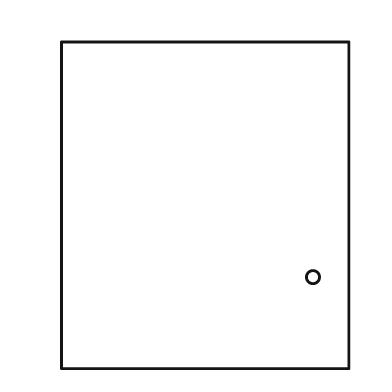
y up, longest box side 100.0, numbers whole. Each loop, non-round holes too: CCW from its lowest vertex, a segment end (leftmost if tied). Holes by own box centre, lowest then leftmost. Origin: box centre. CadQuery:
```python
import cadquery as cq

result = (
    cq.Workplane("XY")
    .moveTo(-44.0, -50.0)
    .lineTo(44.0, -50.0)
    .lineTo(44.0, 50.0)
    .lineTo(-44.0, 50.0)
    .close()
    .moveTo(33.0, -22.0)
    .circle(2.0)
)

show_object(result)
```